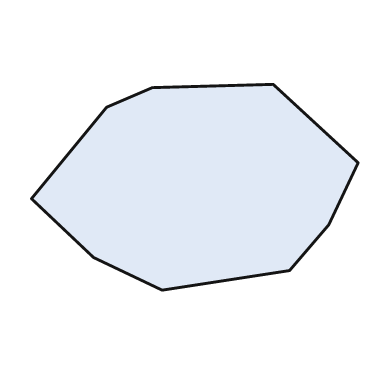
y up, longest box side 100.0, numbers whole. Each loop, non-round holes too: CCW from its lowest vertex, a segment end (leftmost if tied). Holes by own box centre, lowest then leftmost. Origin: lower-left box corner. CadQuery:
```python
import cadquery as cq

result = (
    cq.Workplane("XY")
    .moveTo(40.0, 0.0)
    .lineTo(79.0, 6.0)
    .lineTo(91.0, 20.0)
    .lineTo(100.0, 39.0)
    .lineTo(74.0, 63.0)
    .lineTo(37.0, 62.0)
    .lineTo(23.0, 56.0)
    .lineTo(0.0, 28.0)
    .lineTo(19.0, 10.0)
    .close()
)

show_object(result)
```